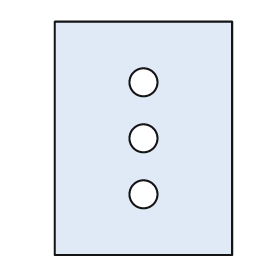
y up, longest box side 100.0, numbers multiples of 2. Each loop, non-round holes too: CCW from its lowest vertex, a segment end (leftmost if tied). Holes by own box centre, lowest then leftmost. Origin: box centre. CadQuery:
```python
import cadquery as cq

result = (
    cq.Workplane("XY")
    .moveTo(-38.0, -50.0)
    .lineTo(38.0, -50.0)
    .lineTo(38.0, 50.0)
    .lineTo(-38.0, 50.0)
    .close()
    .moveTo(0.0, -24.0)
    .circle(6.0)
    .moveTo(0.0, 0.0)
    .circle(6.0)
    .moveTo(0.0, 24.0)
    .circle(6.0)
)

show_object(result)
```